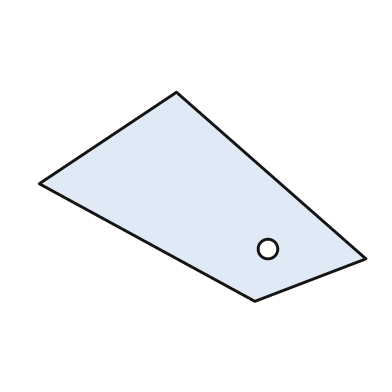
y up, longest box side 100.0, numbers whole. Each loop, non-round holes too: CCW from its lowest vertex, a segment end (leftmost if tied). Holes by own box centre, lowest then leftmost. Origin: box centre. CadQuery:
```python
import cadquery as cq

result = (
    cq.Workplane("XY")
    .moveTo(16.0, -32.0)
    .lineTo(50.0, -19.0)
    .lineTo(-8.0, 32.0)
    .lineTo(-50.0, 4.0)
    .close()
    .moveTo(20.0, -16.0)
    .circle(3.0)
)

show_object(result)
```